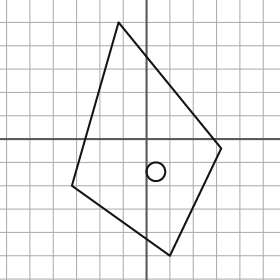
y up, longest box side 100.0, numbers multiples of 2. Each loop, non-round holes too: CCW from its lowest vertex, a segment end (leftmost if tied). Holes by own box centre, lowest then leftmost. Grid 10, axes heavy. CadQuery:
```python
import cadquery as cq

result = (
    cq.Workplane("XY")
    .moveTo(10.0, -50.0)
    .lineTo(32.0, -4.0)
    .lineTo(-12.0, 50.0)
    .lineTo(-32.0, -20.0)
    .close()
    .moveTo(4.0, -14.0)
    .circle(4.0)
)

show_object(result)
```